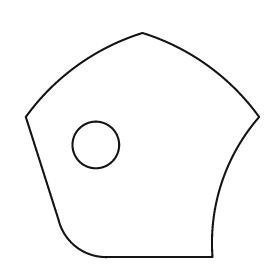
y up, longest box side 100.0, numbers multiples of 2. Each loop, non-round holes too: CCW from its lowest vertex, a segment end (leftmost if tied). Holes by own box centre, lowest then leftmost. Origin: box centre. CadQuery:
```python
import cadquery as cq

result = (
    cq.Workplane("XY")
    .moveTo(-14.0, -48.0)
    .lineTo(30.0, -48.0)
    .threePointArc((34.0, -16.0), (50.0, 12.0))
    .threePointArc((28.0, 34.0), (0.0, 48.0))
    .threePointArc((-28.0, 34.0), (-50.0, 12.0))
    .lineTo(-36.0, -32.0)
    .threePointArc((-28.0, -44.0), (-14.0, -48.0))
    .close()
    .moveTo(-20.0, 0.0)
    .circle(10.0)
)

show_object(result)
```